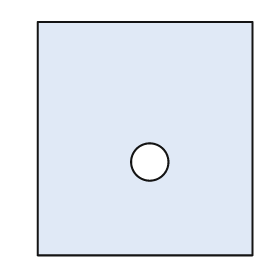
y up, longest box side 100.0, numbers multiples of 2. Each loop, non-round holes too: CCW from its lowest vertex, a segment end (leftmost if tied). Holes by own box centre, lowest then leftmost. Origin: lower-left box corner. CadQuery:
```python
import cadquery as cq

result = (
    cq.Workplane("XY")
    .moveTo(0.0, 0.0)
    .lineTo(92.0, 0.0)
    .lineTo(92.0, 100.0)
    .lineTo(0.0, 100.0)
    .close()
    .moveTo(48.0, 40.0)
    .circle(8.0)
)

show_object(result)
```